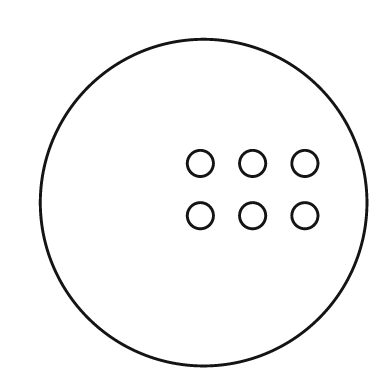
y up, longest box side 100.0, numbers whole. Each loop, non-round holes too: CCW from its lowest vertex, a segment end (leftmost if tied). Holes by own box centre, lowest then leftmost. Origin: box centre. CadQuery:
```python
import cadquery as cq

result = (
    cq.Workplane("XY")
    .moveTo(0.0, 0.0)
    .circle(50.0)
    .moveTo(-1.0, -4.0)
    .circle(4.0)
    .moveTo(15.0, -4.0)
    .circle(4.0)
    .moveTo(31.0, -4.0)
    .circle(4.0)
    .moveTo(-1.0, 12.0)
    .circle(4.0)
    .moveTo(15.0, 12.0)
    .circle(4.0)
    .moveTo(31.0, 12.0)
    .circle(4.0)
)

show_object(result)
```